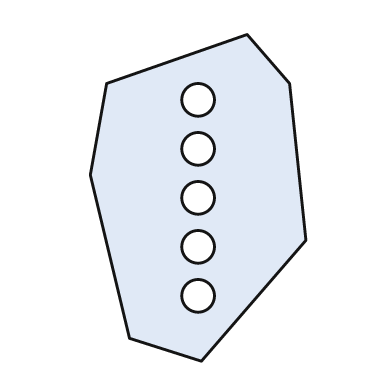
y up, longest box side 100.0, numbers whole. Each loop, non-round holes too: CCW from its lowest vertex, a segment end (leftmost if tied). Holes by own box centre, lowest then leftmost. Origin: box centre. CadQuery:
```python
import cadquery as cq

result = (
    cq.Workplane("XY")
    .moveTo(1.0, -50.0)
    .lineTo(33.0, -13.0)
    .lineTo(28.0, 35.0)
    .lineTo(15.0, 50.0)
    .lineTo(-28.0, 35.0)
    .lineTo(-33.0, 7.0)
    .lineTo(-21.0, -43.0)
    .close()
    .moveTo(0.0, -30.0)
    .circle(5.0)
    .moveTo(0.0, -15.0)
    .circle(5.0)
    .moveTo(0.0, 0.0)
    .circle(5.0)
    .moveTo(0.0, 15.0)
    .circle(5.0)
    .moveTo(0.0, 30.0)
    .circle(5.0)
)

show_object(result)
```